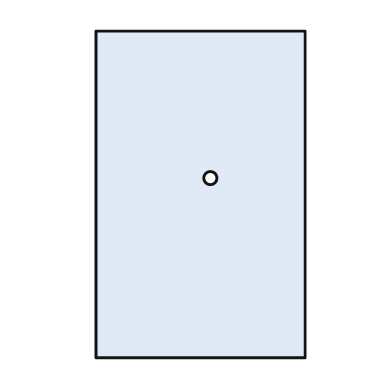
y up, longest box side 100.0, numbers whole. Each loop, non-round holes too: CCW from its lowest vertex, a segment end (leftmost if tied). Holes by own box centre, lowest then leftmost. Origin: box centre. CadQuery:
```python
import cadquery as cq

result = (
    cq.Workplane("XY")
    .moveTo(-32.0, -50.0)
    .lineTo(32.0, -50.0)
    .lineTo(32.0, 50.0)
    .lineTo(-32.0, 50.0)
    .close()
    .moveTo(3.0, 5.0)
    .circle(2.0)
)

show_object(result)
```